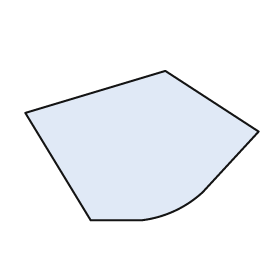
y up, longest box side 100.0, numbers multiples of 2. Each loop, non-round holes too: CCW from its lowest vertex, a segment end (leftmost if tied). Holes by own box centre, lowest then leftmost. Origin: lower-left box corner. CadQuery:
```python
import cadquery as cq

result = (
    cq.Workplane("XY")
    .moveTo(28.0, 0.0)
    .lineTo(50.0, 0.0)
    .threePointArc((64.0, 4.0), (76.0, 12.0))
    .lineTo(100.0, 38.0)
    .lineTo(60.0, 64.0)
    .lineTo(0.0, 46.0)
    .close()
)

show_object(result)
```